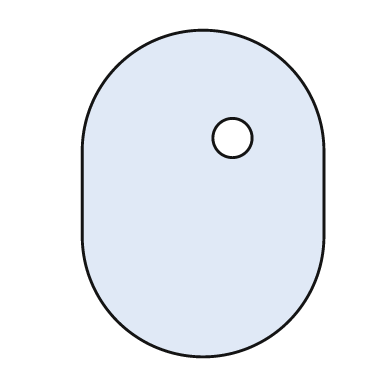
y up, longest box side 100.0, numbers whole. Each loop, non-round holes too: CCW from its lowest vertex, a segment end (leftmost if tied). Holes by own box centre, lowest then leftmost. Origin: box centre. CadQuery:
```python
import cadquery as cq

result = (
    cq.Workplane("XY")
    .moveTo(-37.0, -13.0)
    .threePointArc((0.0, -50.0), (37.0, -13.0))
    .lineTo(37.0, 13.0)
    .threePointArc((0.0, 50.0), (-37.0, 13.0))
    .close()
    .moveTo(9.0, 17.0)
    .circle(6.0)
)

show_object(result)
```